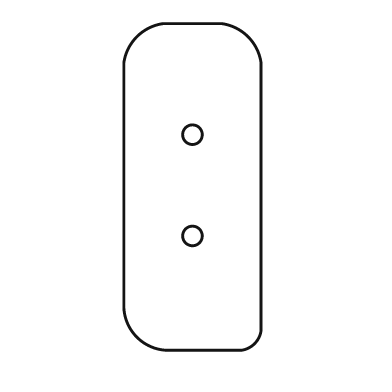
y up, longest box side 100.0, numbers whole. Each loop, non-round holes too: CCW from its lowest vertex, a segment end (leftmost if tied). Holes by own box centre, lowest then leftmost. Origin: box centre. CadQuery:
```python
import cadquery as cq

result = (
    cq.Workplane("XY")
    .moveTo(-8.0, -50.0)
    .lineTo(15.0, -50.0)
    .threePointArc((19.0, -48.0), (21.0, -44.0))
    .lineTo(21.0, 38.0)
    .threePointArc((17.0, 46.0), (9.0, 50.0))
    .lineTo(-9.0, 50.0)
    .threePointArc((-17.0, 46.0), (-21.0, 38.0))
    .lineTo(-21.0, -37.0)
    .threePointArc((-17.0, -46.0), (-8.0, -50.0))
    .close()
    .moveTo(0.0, -15.0)
    .circle(3.0)
    .moveTo(0.0, 16.0)
    .circle(3.0)
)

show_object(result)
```